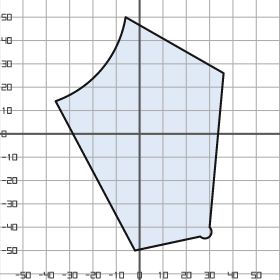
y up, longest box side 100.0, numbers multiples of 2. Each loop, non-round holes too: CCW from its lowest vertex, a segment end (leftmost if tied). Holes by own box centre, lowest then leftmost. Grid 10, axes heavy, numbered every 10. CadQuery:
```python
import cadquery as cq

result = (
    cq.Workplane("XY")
    .moveTo(-2.0, -50.0)
    .lineTo(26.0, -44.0)
    .threePointArc((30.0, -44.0), (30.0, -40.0))
    .lineTo(36.0, 26.0)
    .lineTo(-6.0, 50.0)
    .threePointArc((-16.0, 28.0), (-36.0, 14.0))
    .close()
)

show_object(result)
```